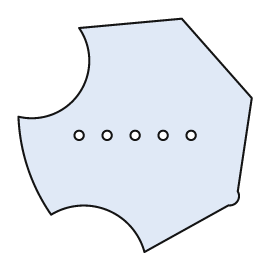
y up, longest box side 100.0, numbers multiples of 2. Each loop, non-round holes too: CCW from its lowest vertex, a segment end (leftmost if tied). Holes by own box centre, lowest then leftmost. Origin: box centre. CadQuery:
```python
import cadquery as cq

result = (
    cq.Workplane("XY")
    .moveTo(4.0, -50.0)
    .lineTo(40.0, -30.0)
    .threePointArc((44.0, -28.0), (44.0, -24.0))
    .lineTo(50.0, 16.0)
    .lineTo(20.0, 50.0)
    .lineTo(-24.0, 46.0)
    .threePointArc((-24.0, 18.0), (-50.0, 8.0))
    .threePointArc((-46.0, -14.0), (-36.0, -34.0))
    .threePointArc((-12.0, -32.0), (4.0, -50.0))
    .close()
    .moveTo(-24.0, 0.0)
    .circle(2.0)
    .moveTo(-12.0, 0.0)
    .circle(2.0)
    .moveTo(0.0, 0.0)
    .circle(2.0)
    .moveTo(12.0, 0.0)
    .circle(2.0)
    .moveTo(24.0, 0.0)
    .circle(2.0)
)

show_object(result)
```